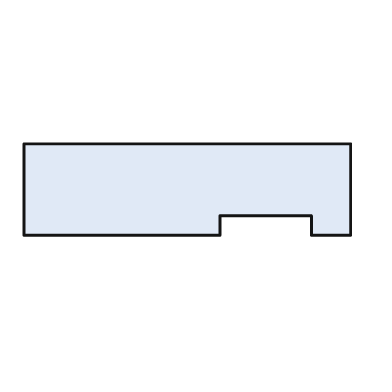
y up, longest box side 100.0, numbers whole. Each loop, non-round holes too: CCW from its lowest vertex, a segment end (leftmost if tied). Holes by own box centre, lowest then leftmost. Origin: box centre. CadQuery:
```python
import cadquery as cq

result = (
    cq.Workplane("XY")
    .moveTo(-50.0, -14.0)
    .lineTo(10.0, -14.0)
    .lineTo(10.0, -8.0)
    .lineTo(38.0, -8.0)
    .lineTo(38.0, -14.0)
    .lineTo(50.0, -14.0)
    .lineTo(50.0, 14.0)
    .lineTo(-50.0, 14.0)
    .close()
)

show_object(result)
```